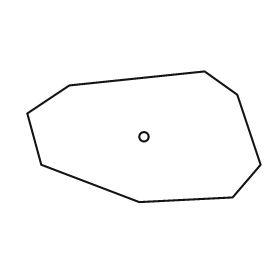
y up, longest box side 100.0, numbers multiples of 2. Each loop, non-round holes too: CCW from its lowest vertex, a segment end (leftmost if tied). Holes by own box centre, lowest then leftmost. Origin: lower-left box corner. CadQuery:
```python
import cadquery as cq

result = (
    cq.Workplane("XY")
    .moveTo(48.0, 0.0)
    .lineTo(88.0, 2.0)
    .lineTo(100.0, 16.0)
    .lineTo(90.0, 46.0)
    .lineTo(76.0, 56.0)
    .lineTo(18.0, 50.0)
    .lineTo(0.0, 38.0)
    .lineTo(6.0, 16.0)
    .close()
    .moveTo(50.0, 28.0)
    .circle(2.0)
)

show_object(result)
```